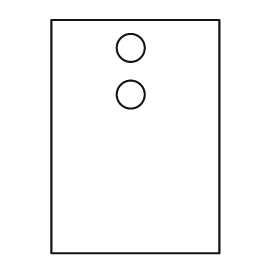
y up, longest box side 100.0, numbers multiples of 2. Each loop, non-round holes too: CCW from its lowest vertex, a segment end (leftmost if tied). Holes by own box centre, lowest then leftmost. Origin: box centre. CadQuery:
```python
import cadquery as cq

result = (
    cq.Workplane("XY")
    .moveTo(-36.0, -50.0)
    .lineTo(36.0, -50.0)
    .lineTo(36.0, 50.0)
    .lineTo(-36.0, 50.0)
    .close()
    .moveTo(-2.0, 18.0)
    .circle(6.0)
    .moveTo(-2.0, 38.0)
    .circle(6.0)
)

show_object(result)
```